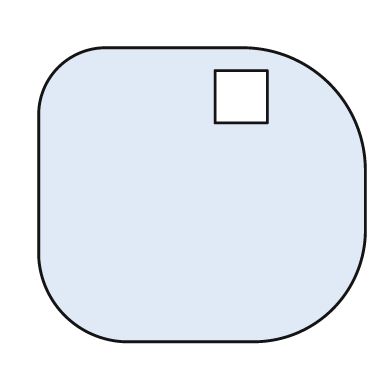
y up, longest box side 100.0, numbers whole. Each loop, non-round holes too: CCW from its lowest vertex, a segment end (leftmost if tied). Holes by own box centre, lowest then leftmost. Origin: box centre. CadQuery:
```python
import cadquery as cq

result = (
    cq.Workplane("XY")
    .moveTo(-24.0, -45.0)
    .lineTo(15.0, -45.0)
    .threePointArc((40.0, -35.0), (50.0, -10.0))
    .lineTo(50.0, 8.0)
    .threePointArc((39.0, 34.0), (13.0, 45.0))
    .lineTo(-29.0, 45.0)
    .threePointArc((-44.0, 39.0), (-50.0, 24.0))
    .lineTo(-50.0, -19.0)
    .threePointArc((-42.0, -37.0), (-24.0, -45.0))
    .close()
    .moveTo(4.0, 22.0)
    .lineTo(20.0, 22.0)
    .lineTo(20.0, 38.0)
    .lineTo(4.0, 38.0)
    .close()
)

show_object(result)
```